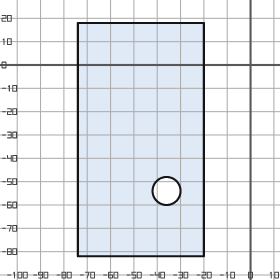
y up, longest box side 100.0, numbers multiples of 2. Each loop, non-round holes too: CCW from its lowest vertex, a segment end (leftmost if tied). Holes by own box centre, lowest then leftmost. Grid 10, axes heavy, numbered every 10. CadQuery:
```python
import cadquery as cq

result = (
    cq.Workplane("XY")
    .moveTo(-74.0, -82.0)
    .lineTo(-20.0, -82.0)
    .lineTo(-20.0, 18.0)
    .lineTo(-74.0, 18.0)
    .close()
    .moveTo(-36.0, -54.0)
    .circle(6.0)
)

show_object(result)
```